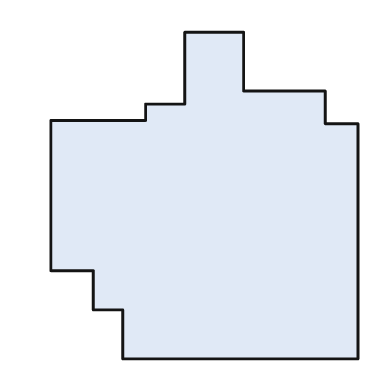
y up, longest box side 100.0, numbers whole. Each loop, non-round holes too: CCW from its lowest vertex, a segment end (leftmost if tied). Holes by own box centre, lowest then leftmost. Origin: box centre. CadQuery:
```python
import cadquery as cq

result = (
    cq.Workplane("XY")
    .moveTo(-25.0, -50.0)
    .lineTo(47.0, -50.0)
    .lineTo(47.0, 22.0)
    .lineTo(37.0, 22.0)
    .lineTo(37.0, 32.0)
    .lineTo(12.0, 32.0)
    .lineTo(12.0, 50.0)
    .lineTo(-6.0, 50.0)
    .lineTo(-6.0, 28.0)
    .lineTo(-18.0, 28.0)
    .lineTo(-18.0, 23.0)
    .lineTo(-47.0, 23.0)
    .lineTo(-47.0, -23.0)
    .lineTo(-34.0, -23.0)
    .lineTo(-34.0, -35.0)
    .lineTo(-25.0, -35.0)
    .close()
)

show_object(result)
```